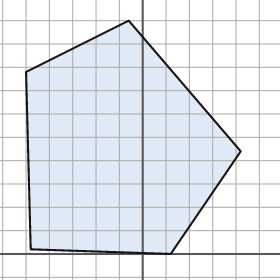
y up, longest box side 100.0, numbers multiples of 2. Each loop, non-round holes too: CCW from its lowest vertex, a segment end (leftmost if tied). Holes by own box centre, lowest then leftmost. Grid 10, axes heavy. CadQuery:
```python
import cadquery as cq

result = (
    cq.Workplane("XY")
    .moveTo(12.0, 0.0)
    .lineTo(42.0, 44.0)
    .lineTo(-6.0, 100.0)
    .lineTo(-50.0, 78.0)
    .lineTo(-48.0, 2.0)
    .close()
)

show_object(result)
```